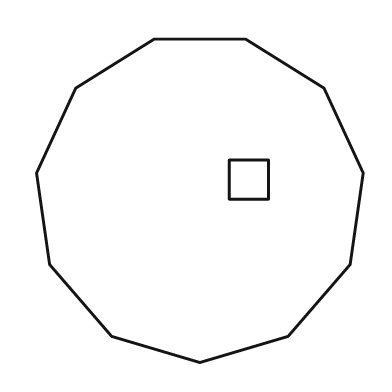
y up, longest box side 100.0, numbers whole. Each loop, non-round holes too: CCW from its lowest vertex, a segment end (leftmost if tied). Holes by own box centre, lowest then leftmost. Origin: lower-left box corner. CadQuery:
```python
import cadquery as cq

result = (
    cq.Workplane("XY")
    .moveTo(50.0, 0.0)
    .lineTo(77.0, 8.0)
    .lineTo(96.0, 30.0)
    .lineTo(100.0, 58.0)
    .lineTo(88.0, 84.0)
    .lineTo(64.0, 99.0)
    .lineTo(36.0, 99.0)
    .lineTo(12.0, 84.0)
    .lineTo(0.0, 58.0)
    .lineTo(4.0, 30.0)
    .lineTo(23.0, 8.0)
    .close()
    .moveTo(59.0, 50.0)
    .lineTo(71.0, 50.0)
    .lineTo(71.0, 62.0)
    .lineTo(59.0, 62.0)
    .close()
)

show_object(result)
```